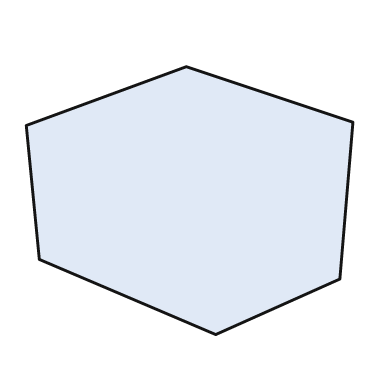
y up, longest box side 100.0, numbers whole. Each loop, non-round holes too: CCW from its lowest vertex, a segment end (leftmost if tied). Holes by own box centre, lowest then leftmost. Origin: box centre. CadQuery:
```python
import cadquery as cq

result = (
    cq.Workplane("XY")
    .moveTo(8.0, -41.0)
    .lineTo(46.0, -24.0)
    .lineTo(50.0, 24.0)
    .lineTo(-1.0, 41.0)
    .lineTo(-50.0, 23.0)
    .lineTo(-46.0, -18.0)
    .close()
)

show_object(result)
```